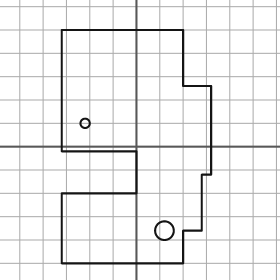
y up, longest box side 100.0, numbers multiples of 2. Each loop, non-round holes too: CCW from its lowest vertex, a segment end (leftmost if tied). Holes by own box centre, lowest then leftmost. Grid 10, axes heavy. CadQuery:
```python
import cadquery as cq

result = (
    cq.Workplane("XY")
    .moveTo(-32.0, -50.0)
    .lineTo(20.0, -50.0)
    .lineTo(20.0, -36.0)
    .lineTo(28.0, -36.0)
    .lineTo(28.0, -12.0)
    .lineTo(32.0, -12.0)
    .lineTo(32.0, 26.0)
    .lineTo(20.0, 26.0)
    .lineTo(20.0, 50.0)
    .lineTo(-32.0, 50.0)
    .lineTo(-32.0, -2.0)
    .lineTo(0.0, -2.0)
    .lineTo(0.0, -20.0)
    .lineTo(-32.0, -20.0)
    .close()
    .moveTo(12.0, -36.0)
    .circle(4.0)
    .moveTo(-22.0, 10.0)
    .circle(2.0)
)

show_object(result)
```